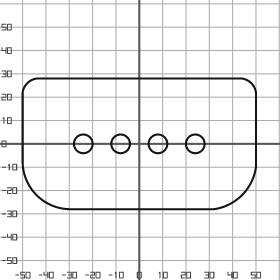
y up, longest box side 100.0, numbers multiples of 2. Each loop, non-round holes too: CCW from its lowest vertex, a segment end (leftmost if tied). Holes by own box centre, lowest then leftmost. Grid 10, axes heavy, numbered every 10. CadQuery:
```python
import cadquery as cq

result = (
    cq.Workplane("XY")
    .moveTo(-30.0, -28.0)
    .lineTo(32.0, -28.0)
    .threePointArc((44.0, -22.0), (50.0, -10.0))
    .lineTo(50.0, 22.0)
    .threePointArc((48.0, 26.0), (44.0, 28.0))
    .lineTo(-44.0, 28.0)
    .threePointArc((-48.0, 26.0), (-50.0, 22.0))
    .lineTo(-50.0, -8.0)
    .threePointArc((-44.0, -22.0), (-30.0, -28.0))
    .close()
    .moveTo(-24.0, 0.0)
    .circle(4.0)
    .moveTo(-8.0, 0.0)
    .circle(4.0)
    .moveTo(8.0, 0.0)
    .circle(4.0)
    .moveTo(24.0, 0.0)
    .circle(4.0)
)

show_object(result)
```